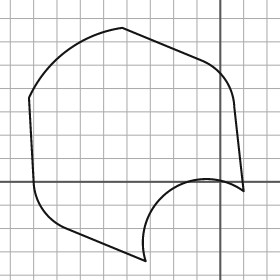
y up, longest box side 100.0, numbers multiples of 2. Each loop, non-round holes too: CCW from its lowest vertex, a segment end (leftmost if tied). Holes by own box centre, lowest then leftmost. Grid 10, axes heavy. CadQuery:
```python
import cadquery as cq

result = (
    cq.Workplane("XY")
    .moveTo(-32.0, -34.0)
    .threePointArc((-22.0, -4.0), (10.0, -4.0))
    .lineTo(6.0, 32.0)
    .threePointArc((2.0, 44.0), (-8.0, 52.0))
    .lineTo(-42.0, 66.0)
    .threePointArc((-66.0, 56.0), (-82.0, 36.0))
    .lineTo(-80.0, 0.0)
    .threePointArc((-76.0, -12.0), (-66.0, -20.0))
    .close()
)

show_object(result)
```